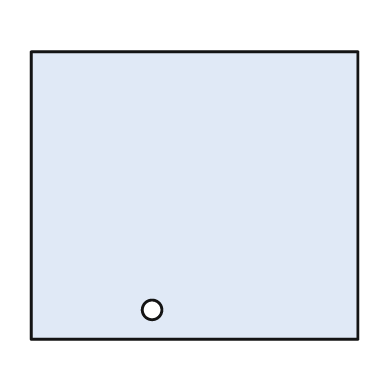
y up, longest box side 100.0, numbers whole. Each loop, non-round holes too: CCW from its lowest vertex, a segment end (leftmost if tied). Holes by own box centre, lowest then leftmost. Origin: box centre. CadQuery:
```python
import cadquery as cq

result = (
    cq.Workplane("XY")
    .moveTo(-50.0, -44.0)
    .lineTo(50.0, -44.0)
    .lineTo(50.0, 44.0)
    .lineTo(-50.0, 44.0)
    .close()
    .moveTo(-13.0, -35.0)
    .circle(3.0)
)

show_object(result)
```